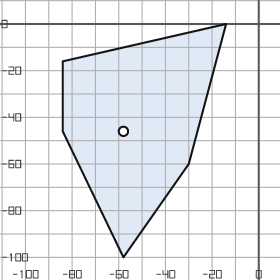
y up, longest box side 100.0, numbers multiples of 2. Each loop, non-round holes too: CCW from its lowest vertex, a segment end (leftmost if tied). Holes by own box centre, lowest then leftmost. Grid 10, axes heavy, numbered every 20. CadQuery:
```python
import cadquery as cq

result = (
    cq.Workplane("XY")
    .moveTo(-58.0, -100.0)
    .lineTo(-30.0, -60.0)
    .lineTo(-14.0, 0.0)
    .lineTo(-84.0, -16.0)
    .lineTo(-84.0, -46.0)
    .close()
    .moveTo(-58.0, -46.0)
    .circle(2.0)
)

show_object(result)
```